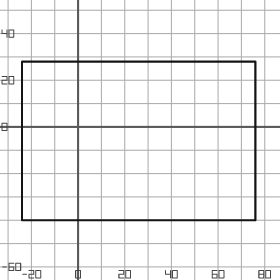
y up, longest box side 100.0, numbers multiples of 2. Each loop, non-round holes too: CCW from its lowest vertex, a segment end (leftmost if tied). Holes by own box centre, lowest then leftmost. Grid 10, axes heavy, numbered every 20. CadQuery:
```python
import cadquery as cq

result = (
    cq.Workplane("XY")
    .moveTo(-24.0, -40.0)
    .lineTo(76.0, -40.0)
    .lineTo(76.0, 28.0)
    .lineTo(-24.0, 28.0)
    .close()
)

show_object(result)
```